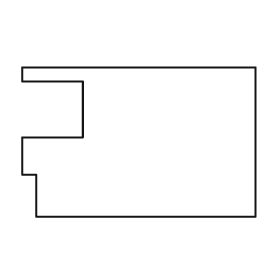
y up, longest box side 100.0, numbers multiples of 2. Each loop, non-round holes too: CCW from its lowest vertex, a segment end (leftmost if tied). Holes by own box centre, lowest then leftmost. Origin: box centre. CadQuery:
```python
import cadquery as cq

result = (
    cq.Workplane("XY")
    .moveTo(-44.0, -32.0)
    .lineTo(50.0, -32.0)
    .lineTo(50.0, 32.0)
    .lineTo(-50.0, 32.0)
    .lineTo(-50.0, 26.0)
    .lineTo(-24.0, 26.0)
    .lineTo(-24.0, 2.0)
    .lineTo(-50.0, 2.0)
    .lineTo(-50.0, -14.0)
    .lineTo(-44.0, -14.0)
    .close()
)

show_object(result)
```